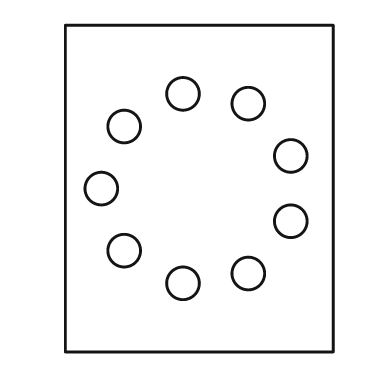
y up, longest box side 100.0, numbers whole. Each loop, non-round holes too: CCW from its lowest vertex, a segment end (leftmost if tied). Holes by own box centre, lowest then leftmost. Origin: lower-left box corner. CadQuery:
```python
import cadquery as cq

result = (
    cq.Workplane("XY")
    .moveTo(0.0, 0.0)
    .lineTo(82.0, 0.0)
    .lineTo(82.0, 100.0)
    .lineTo(0.0, 100.0)
    .close()
    .moveTo(36.0, 21.0)
    .circle(5.0)
    .moveTo(56.0, 24.0)
    .circle(5.0)
    .moveTo(18.0, 31.0)
    .circle(5.0)
    .moveTo(69.0, 40.0)
    .circle(5.0)
    .moveTo(11.0, 50.0)
    .circle(5.0)
    .moveTo(69.0, 60.0)
    .circle(5.0)
    .moveTo(18.0, 69.0)
    .circle(5.0)
    .moveTo(56.0, 76.0)
    .circle(5.0)
    .moveTo(36.0, 79.0)
    .circle(5.0)
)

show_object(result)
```